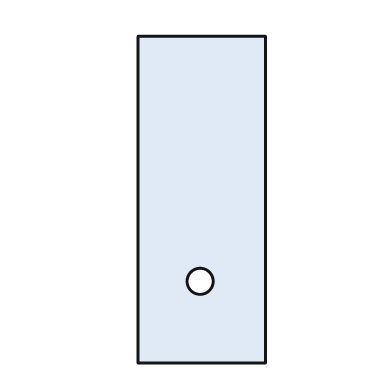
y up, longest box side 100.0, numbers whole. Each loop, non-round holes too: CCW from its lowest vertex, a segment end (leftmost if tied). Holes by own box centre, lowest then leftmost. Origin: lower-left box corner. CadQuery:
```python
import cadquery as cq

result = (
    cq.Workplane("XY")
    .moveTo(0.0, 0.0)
    .lineTo(39.0, 0.0)
    .lineTo(39.0, 100.0)
    .lineTo(0.0, 100.0)
    .close()
    .moveTo(19.0, 25.0)
    .circle(4.0)
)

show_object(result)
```